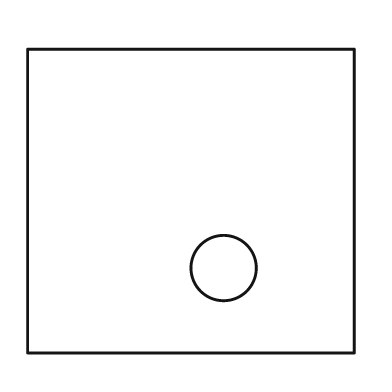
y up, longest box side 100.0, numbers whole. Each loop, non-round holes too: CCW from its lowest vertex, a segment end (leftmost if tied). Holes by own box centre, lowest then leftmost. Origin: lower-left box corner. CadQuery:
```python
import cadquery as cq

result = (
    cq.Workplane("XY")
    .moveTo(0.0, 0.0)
    .lineTo(100.0, 0.0)
    .lineTo(100.0, 93.0)
    .lineTo(0.0, 93.0)
    .close()
    .moveTo(60.0, 26.0)
    .circle(10.0)
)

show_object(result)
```